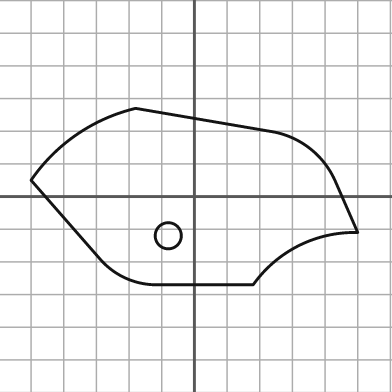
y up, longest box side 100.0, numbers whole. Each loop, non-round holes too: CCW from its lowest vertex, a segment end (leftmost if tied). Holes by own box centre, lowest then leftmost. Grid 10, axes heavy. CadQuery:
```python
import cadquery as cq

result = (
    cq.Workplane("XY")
    .moveTo(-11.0, -27.0)
    .lineTo(18.0, -27.0)
    .threePointArc((32.0, -15.0), (50.0, -11.0))
    .lineTo(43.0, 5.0)
    .threePointArc((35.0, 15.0), (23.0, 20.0))
    .lineTo(-18.0, 27.0)
    .threePointArc((-36.0, 19.0), (-50.0, 5.0))
    .lineTo(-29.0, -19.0)
    .threePointArc((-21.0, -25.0), (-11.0, -27.0))
    .close()
    .moveTo(-8.0, -12.0)
    .circle(4.0)
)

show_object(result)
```